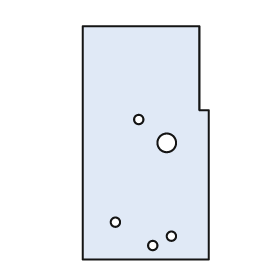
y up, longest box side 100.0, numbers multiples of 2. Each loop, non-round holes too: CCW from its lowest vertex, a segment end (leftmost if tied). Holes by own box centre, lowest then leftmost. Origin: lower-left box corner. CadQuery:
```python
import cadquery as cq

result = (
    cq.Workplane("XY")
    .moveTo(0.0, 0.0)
    .lineTo(54.0, 0.0)
    .lineTo(54.0, 64.0)
    .lineTo(50.0, 64.0)
    .lineTo(50.0, 100.0)
    .lineTo(0.0, 100.0)
    .close()
    .moveTo(30.0, 6.0)
    .circle(2.0)
    .moveTo(38.0, 10.0)
    .circle(2.0)
    .moveTo(14.0, 16.0)
    .circle(2.0)
    .moveTo(36.0, 50.0)
    .circle(4.0)
    .moveTo(24.0, 60.0)
    .circle(2.0)
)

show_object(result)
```